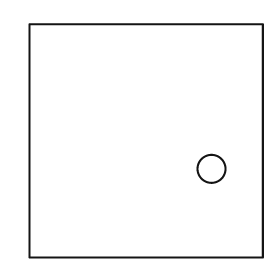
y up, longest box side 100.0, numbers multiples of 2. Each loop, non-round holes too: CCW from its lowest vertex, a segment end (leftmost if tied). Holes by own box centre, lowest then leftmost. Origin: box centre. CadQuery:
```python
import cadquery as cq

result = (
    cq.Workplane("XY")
    .moveTo(-50.0, -50.0)
    .lineTo(50.0, -50.0)
    .lineTo(50.0, 50.0)
    .lineTo(-50.0, 50.0)
    .close()
    .moveTo(28.0, -12.0)
    .circle(6.0)
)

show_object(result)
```